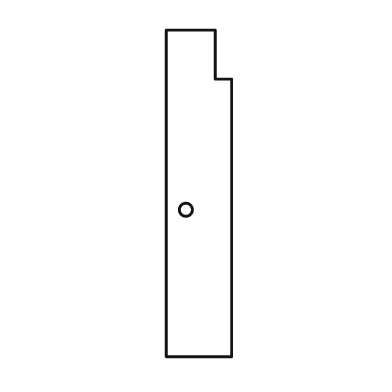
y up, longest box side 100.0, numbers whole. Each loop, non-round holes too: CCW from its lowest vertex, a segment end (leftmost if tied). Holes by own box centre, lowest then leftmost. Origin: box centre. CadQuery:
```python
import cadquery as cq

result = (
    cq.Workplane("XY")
    .moveTo(-10.0, -50.0)
    .lineTo(10.0, -50.0)
    .lineTo(10.0, 35.0)
    .lineTo(5.0, 35.0)
    .lineTo(5.0, 50.0)
    .lineTo(-10.0, 50.0)
    .close()
    .moveTo(-4.0, -5.0)
    .circle(2.0)
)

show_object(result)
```